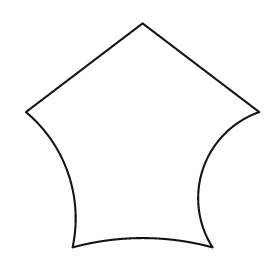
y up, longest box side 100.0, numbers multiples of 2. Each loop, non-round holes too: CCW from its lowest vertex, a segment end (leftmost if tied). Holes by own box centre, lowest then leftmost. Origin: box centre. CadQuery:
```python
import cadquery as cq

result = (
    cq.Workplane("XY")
    .moveTo(-30.0, -48.0)
    .threePointArc((0.0, -44.0), (30.0, -48.0))
    .threePointArc((26.0, -14.0), (50.0, 10.0))
    .lineTo(0.0, 48.0)
    .lineTo(-50.0, 10.0)
    .threePointArc((-32.0, -16.0), (-30.0, -48.0))
    .close()
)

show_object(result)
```